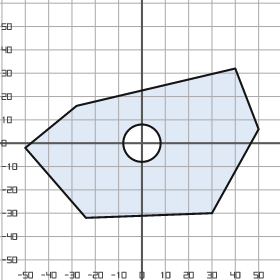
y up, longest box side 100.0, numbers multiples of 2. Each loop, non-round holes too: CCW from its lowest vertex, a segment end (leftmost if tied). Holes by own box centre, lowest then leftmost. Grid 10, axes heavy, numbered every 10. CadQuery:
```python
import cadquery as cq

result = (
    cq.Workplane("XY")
    .moveTo(-24.0, -32.0)
    .lineTo(30.0, -30.0)
    .lineTo(50.0, 6.0)
    .lineTo(40.0, 32.0)
    .lineTo(-28.0, 16.0)
    .lineTo(-50.0, -2.0)
    .close()
    .moveTo(0.0, 0.0)
    .circle(8.0)
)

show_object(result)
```